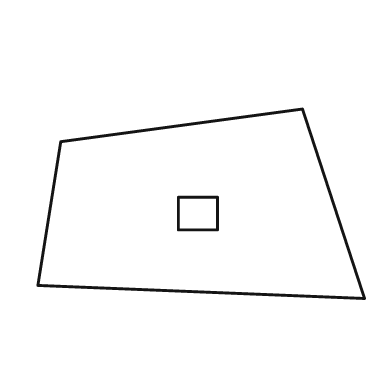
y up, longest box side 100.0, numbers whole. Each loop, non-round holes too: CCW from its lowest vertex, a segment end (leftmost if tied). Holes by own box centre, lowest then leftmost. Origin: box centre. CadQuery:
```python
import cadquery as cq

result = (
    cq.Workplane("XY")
    .moveTo(50.0, -29.0)
    .lineTo(31.0, 29.0)
    .lineTo(-43.0, 19.0)
    .lineTo(-50.0, -25.0)
    .close()
    .moveTo(-7.0, -8.0)
    .lineTo(5.0, -8.0)
    .lineTo(5.0, 2.0)
    .lineTo(-7.0, 2.0)
    .close()
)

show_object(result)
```